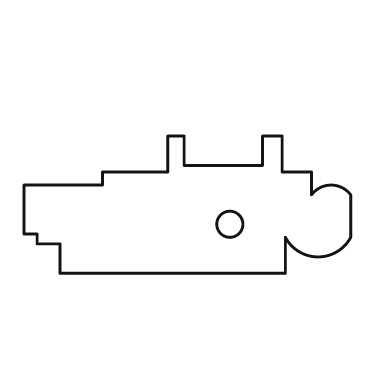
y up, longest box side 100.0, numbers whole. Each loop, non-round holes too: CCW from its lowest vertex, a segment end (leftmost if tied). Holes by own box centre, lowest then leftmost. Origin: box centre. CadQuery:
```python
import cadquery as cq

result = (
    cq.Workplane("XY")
    .moveTo(-39.0, -21.0)
    .lineTo(30.0, -21.0)
    .lineTo(30.0, -10.0)
    .threePointArc((40.0, -16.0), (50.0, -10.0))
    .lineTo(50.0, 3.0)
    .threePointArc((44.0, 6.0), (38.0, 3.0))
    .lineTo(38.0, 10.0)
    .lineTo(29.0, 10.0)
    .lineTo(29.0, 21.0)
    .lineTo(23.0, 21.0)
    .lineTo(23.0, 12.0)
    .lineTo(-1.0, 12.0)
    .lineTo(-1.0, 21.0)
    .lineTo(-6.0, 21.0)
    .lineTo(-6.0, 10.0)
    .lineTo(-26.0, 10.0)
    .lineTo(-26.0, 6.0)
    .lineTo(-50.0, 6.0)
    .lineTo(-50.0, -9.0)
    .lineTo(-46.0, -9.0)
    .lineTo(-46.0, -12.0)
    .lineTo(-39.0, -12.0)
    .close()
    .moveTo(13.0, -6.0)
    .circle(4.0)
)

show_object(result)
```